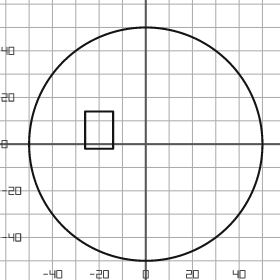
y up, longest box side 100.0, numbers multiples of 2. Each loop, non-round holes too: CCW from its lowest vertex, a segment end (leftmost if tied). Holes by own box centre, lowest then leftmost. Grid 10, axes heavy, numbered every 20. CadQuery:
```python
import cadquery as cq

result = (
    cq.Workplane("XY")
    .moveTo(0.0, 0.0)
    .circle(50.0)
    .moveTo(-26.0, -2.0)
    .lineTo(-14.0, -2.0)
    .lineTo(-14.0, 14.0)
    .lineTo(-26.0, 14.0)
    .close()
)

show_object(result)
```